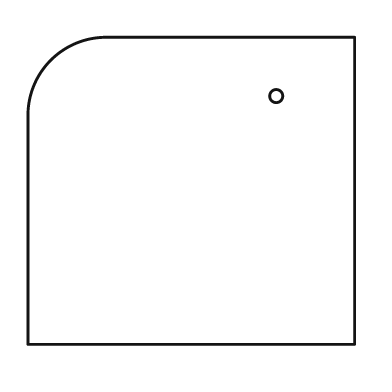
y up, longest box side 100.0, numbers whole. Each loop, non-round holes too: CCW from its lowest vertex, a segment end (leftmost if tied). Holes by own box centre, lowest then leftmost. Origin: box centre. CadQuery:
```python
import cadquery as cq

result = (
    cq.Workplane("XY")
    .moveTo(-50.0, -47.0)
    .lineTo(50.0, -47.0)
    .lineTo(50.0, 47.0)
    .lineTo(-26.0, 47.0)
    .threePointArc((-43.0, 40.0), (-50.0, 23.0))
    .close()
    .moveTo(26.0, 29.0)
    .circle(2.0)
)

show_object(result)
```